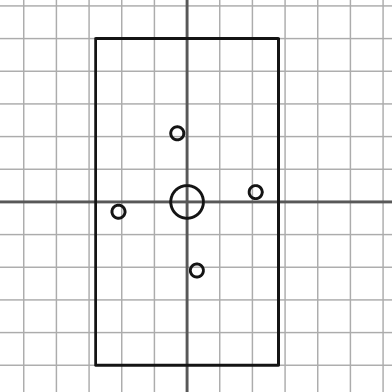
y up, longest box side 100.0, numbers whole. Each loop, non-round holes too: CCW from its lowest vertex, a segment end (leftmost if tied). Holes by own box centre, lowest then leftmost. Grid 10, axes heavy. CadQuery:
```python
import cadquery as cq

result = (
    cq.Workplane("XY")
    .moveTo(-28.0, -50.0)
    .lineTo(28.0, -50.0)
    .lineTo(28.0, 50.0)
    .lineTo(-28.0, 50.0)
    .close()
    .moveTo(3.0, -21.0)
    .circle(2.0)
    .moveTo(-21.0, -3.0)
    .circle(2.0)
    .moveTo(0.0, 0.0)
    .circle(5.0)
    .moveTo(21.0, 3.0)
    .circle(2.0)
    .moveTo(-3.0, 21.0)
    .circle(2.0)
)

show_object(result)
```